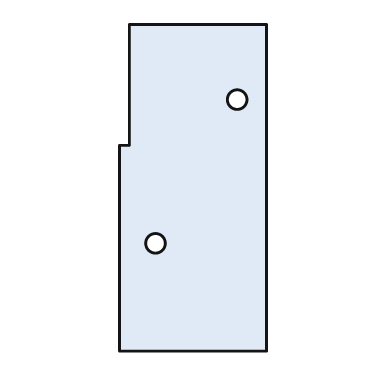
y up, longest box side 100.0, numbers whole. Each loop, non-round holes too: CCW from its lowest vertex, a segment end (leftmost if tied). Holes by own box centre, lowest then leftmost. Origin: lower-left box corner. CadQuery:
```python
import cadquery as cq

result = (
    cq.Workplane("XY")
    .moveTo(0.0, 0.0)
    .lineTo(45.0, 0.0)
    .lineTo(45.0, 100.0)
    .lineTo(3.0, 100.0)
    .lineTo(3.0, 63.0)
    .lineTo(0.0, 63.0)
    .close()
    .moveTo(11.0, 33.0)
    .circle(3.0)
    .moveTo(36.0, 77.0)
    .circle(3.0)
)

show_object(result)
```